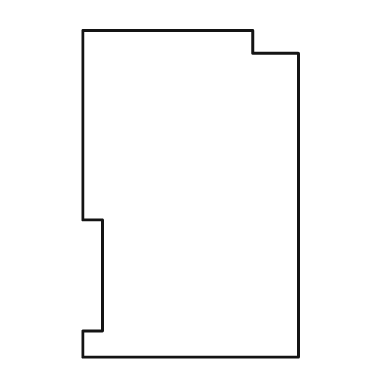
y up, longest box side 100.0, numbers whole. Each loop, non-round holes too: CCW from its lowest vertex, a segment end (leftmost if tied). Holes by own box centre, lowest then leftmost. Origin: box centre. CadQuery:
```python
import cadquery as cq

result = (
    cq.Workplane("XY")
    .moveTo(-33.0, -50.0)
    .lineTo(33.0, -50.0)
    .lineTo(33.0, 43.0)
    .lineTo(19.0, 43.0)
    .lineTo(19.0, 50.0)
    .lineTo(-33.0, 50.0)
    .lineTo(-33.0, -8.0)
    .lineTo(-27.0, -8.0)
    .lineTo(-27.0, -42.0)
    .lineTo(-33.0, -42.0)
    .close()
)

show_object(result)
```